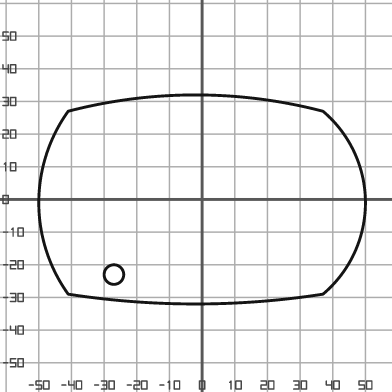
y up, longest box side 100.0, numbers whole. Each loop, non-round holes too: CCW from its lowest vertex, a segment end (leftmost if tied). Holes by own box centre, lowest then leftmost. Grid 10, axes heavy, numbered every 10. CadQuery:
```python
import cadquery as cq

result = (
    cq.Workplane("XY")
    .moveTo(-41.0, -29.0)
    .threePointArc((-2.0, -32.0), (37.0, -29.0))
    .threePointArc((50.0, -1.0), (37.0, 27.0))
    .threePointArc((-2.0, 32.0), (-41.0, 27.0))
    .threePointArc((-50.0, -1.0), (-41.0, -29.0))
    .close()
    .moveTo(-27.0, -23.0)
    .circle(3.0)
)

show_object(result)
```